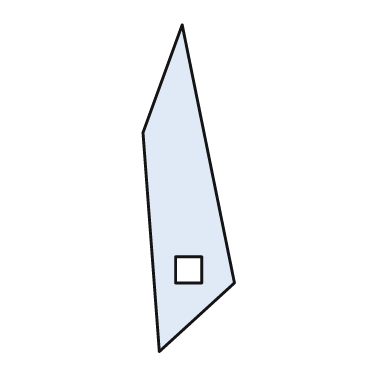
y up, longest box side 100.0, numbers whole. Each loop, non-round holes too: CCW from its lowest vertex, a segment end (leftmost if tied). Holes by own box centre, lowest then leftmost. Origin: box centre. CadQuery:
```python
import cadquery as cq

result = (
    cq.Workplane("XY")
    .moveTo(-9.0, -50.0)
    .lineTo(14.0, -29.0)
    .lineTo(-2.0, 50.0)
    .lineTo(-14.0, 17.0)
    .close()
    .moveTo(-4.0, -29.0)
    .lineTo(4.0, -29.0)
    .lineTo(4.0, -21.0)
    .lineTo(-4.0, -21.0)
    .close()
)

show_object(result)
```